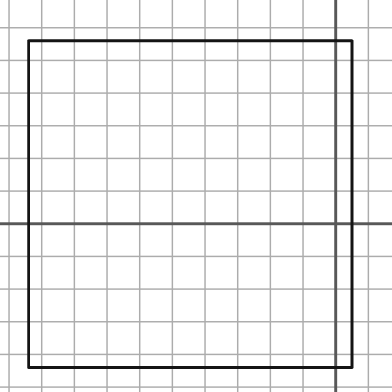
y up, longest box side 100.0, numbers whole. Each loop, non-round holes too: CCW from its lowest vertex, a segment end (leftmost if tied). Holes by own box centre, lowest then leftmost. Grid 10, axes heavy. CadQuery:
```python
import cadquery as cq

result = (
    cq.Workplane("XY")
    .moveTo(-94.0, -44.0)
    .lineTo(5.0, -44.0)
    .lineTo(5.0, 56.0)
    .lineTo(-94.0, 56.0)
    .close()
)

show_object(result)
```